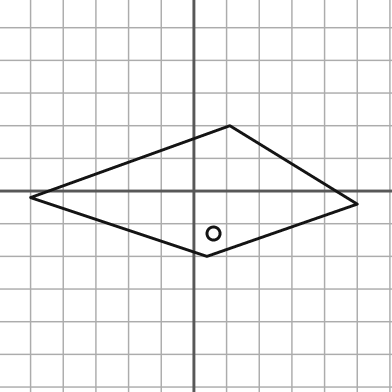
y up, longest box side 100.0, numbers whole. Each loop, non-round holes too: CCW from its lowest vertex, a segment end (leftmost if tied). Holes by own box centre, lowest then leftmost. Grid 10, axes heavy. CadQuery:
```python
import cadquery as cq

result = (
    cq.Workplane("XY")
    .moveTo(4.0, -20.0)
    .lineTo(50.0, -4.0)
    .lineTo(11.0, 20.0)
    .lineTo(-50.0, -2.0)
    .close()
    .moveTo(6.0, -13.0)
    .circle(2.0)
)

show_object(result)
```